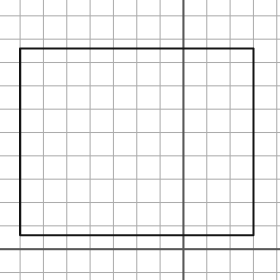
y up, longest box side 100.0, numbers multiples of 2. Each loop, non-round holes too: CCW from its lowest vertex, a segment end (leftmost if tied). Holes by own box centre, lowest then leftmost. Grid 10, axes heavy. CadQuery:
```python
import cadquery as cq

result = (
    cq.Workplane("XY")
    .moveTo(-70.0, 6.0)
    .lineTo(30.0, 6.0)
    .lineTo(30.0, 86.0)
    .lineTo(-70.0, 86.0)
    .close()
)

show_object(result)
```